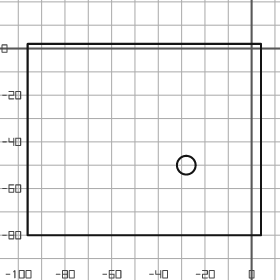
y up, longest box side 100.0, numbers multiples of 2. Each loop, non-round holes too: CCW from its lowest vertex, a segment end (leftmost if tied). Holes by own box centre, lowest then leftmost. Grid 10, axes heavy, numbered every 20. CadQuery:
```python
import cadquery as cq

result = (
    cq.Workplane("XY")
    .moveTo(-96.0, -80.0)
    .lineTo(4.0, -80.0)
    .lineTo(4.0, 2.0)
    .lineTo(-96.0, 2.0)
    .close()
    .moveTo(-28.0, -50.0)
    .circle(4.0)
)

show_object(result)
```